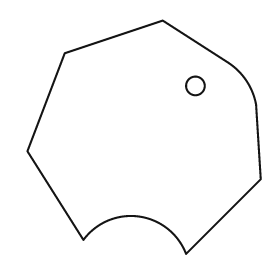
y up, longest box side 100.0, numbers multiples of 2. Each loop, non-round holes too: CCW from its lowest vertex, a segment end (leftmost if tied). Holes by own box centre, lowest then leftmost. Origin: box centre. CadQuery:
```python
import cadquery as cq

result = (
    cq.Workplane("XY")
    .moveTo(18.0, -50.0)
    .lineTo(50.0, -18.0)
    .lineTo(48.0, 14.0)
    .threePointArc((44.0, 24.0), (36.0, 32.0))
    .lineTo(8.0, 50.0)
    .lineTo(-34.0, 36.0)
    .lineTo(-50.0, -6.0)
    .lineTo(-26.0, -44.0)
    .threePointArc((-2.0, -34.0), (18.0, -50.0))
    .close()
    .moveTo(22.0, 22.0)
    .circle(4.0)
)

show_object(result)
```